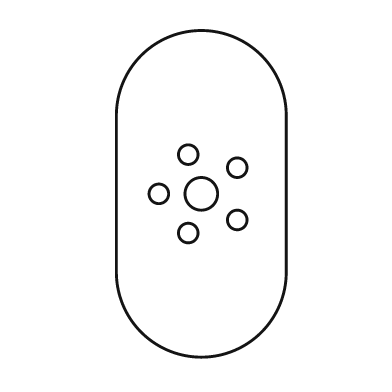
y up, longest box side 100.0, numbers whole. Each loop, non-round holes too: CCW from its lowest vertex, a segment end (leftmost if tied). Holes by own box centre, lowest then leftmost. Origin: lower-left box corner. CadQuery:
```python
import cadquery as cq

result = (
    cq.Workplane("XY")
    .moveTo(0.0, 26.0)
    .threePointArc((26.0, 0.0), (52.0, 26.0))
    .lineTo(52.0, 74.0)
    .threePointArc((26.0, 100.0), (0.0, 74.0))
    .close()
    .moveTo(22.0, 38.0)
    .circle(3.0)
    .moveTo(37.0, 42.0)
    .circle(3.0)
    .moveTo(13.0, 50.0)
    .circle(3.0)
    .moveTo(26.0, 50.0)
    .circle(5.0)
    .moveTo(37.0, 58.0)
    .circle(3.0)
    .moveTo(22.0, 62.0)
    .circle(3.0)
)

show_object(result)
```